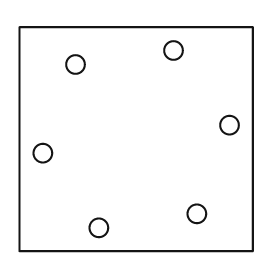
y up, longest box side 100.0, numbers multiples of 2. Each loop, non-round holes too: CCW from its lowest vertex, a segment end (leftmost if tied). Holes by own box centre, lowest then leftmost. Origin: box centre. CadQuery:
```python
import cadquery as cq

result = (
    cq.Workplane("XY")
    .moveTo(-50.0, -48.0)
    .lineTo(50.0, -48.0)
    .lineTo(50.0, 48.0)
    .lineTo(-50.0, 48.0)
    .close()
    .moveTo(-16.0, -38.0)
    .circle(4.0)
    .moveTo(26.0, -32.0)
    .circle(4.0)
    .moveTo(-40.0, -6.0)
    .circle(4.0)
    .moveTo(40.0, 6.0)
    .circle(4.0)
    .moveTo(-26.0, 32.0)
    .circle(4.0)
    .moveTo(16.0, 38.0)
    .circle(4.0)
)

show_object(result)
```